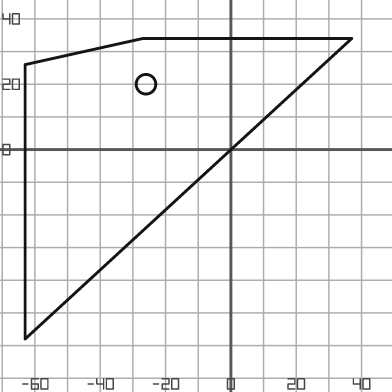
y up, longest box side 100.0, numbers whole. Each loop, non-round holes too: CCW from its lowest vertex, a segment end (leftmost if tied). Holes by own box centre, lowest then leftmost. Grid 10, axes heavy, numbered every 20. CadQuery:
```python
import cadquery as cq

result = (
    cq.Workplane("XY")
    .moveTo(-63.0, -58.0)
    .lineTo(37.0, 34.0)
    .lineTo(-27.0, 34.0)
    .lineTo(-63.0, 26.0)
    .close()
    .moveTo(-26.0, 20.0)
    .circle(3.0)
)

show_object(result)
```